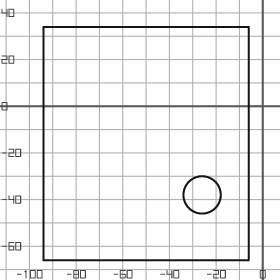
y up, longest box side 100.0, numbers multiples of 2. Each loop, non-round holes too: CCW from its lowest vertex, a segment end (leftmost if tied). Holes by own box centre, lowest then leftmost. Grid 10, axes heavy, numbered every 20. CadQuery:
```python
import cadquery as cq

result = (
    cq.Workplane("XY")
    .moveTo(-94.0, -66.0)
    .lineTo(-6.0, -66.0)
    .lineTo(-6.0, 34.0)
    .lineTo(-94.0, 34.0)
    .close()
    .moveTo(-26.0, -38.0)
    .circle(8.0)
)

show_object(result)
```